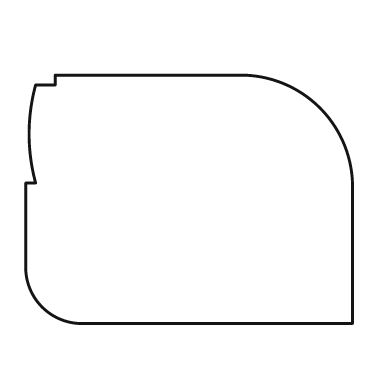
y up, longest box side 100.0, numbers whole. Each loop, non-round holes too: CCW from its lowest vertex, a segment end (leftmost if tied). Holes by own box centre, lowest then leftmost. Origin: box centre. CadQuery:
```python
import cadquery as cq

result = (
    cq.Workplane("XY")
    .moveTo(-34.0, -38.0)
    .lineTo(50.0, -38.0)
    .lineTo(50.0, 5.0)
    .threePointArc((40.0, 28.0), (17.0, 38.0))
    .lineTo(-41.0, 38.0)
    .lineTo(-41.0, 35.0)
    .lineTo(-47.0, 35.0)
    .threePointArc((-49.0, 20.0), (-47.0, 5.0))
    .lineTo(-50.0, 5.0)
    .lineTo(-50.0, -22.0)
    .threePointArc((-45.0, -33.0), (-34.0, -38.0))
    .close()
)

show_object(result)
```